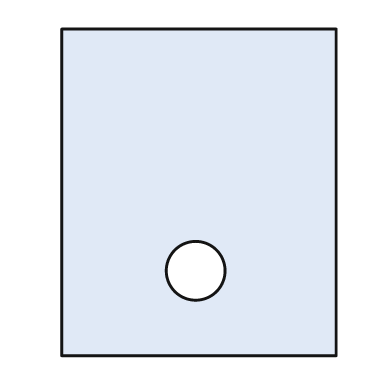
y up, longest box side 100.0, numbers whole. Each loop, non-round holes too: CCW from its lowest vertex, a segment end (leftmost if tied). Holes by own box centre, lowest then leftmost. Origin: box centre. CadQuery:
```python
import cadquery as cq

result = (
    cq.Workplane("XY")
    .moveTo(-42.0, -50.0)
    .lineTo(42.0, -50.0)
    .lineTo(42.0, 50.0)
    .lineTo(-42.0, 50.0)
    .close()
    .moveTo(-1.0, -24.0)
    .circle(9.0)
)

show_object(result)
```